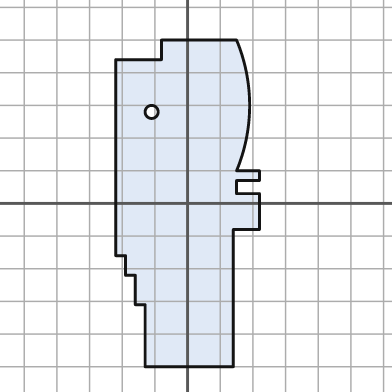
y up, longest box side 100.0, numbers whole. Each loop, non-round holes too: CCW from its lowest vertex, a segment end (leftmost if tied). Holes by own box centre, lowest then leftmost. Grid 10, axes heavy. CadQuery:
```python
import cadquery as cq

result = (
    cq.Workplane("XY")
    .moveTo(-13.0, -50.0)
    .lineTo(14.0, -50.0)
    .lineTo(14.0, -8.0)
    .lineTo(22.0, -8.0)
    .lineTo(22.0, 3.0)
    .lineTo(15.0, 3.0)
    .lineTo(15.0, 7.0)
    .lineTo(22.0, 7.0)
    .lineTo(22.0, 10.0)
    .lineTo(15.0, 10.0)
    .threePointArc((19.0, 30.0), (15.0, 50.0))
    .lineTo(-8.0, 50.0)
    .lineTo(-8.0, 44.0)
    .lineTo(-22.0, 44.0)
    .lineTo(-22.0, -16.0)
    .lineTo(-19.0, -16.0)
    .lineTo(-19.0, -22.0)
    .lineTo(-16.0, -22.0)
    .lineTo(-16.0, -31.0)
    .lineTo(-13.0, -31.0)
    .close()
    .moveTo(-11.0, 28.0)
    .circle(2.0)
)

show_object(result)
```